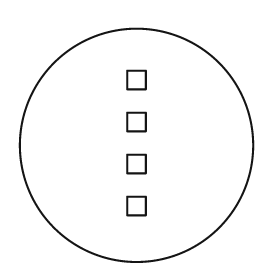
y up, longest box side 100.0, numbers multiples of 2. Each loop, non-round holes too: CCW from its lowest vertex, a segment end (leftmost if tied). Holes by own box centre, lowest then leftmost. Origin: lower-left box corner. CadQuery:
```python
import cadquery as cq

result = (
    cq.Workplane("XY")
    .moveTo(50.0, 50.0)
    .circle(50.0)
    .moveTo(46.0, 20.0)
    .lineTo(54.0, 20.0)
    .lineTo(54.0, 28.0)
    .lineTo(46.0, 28.0)
    .close()
    .moveTo(46.0, 38.0)
    .lineTo(54.0, 38.0)
    .lineTo(54.0, 46.0)
    .lineTo(46.0, 46.0)
    .close()
    .moveTo(46.0, 56.0)
    .lineTo(54.0, 56.0)
    .lineTo(54.0, 64.0)
    .lineTo(46.0, 64.0)
    .close()
    .moveTo(46.0, 74.0)
    .lineTo(54.0, 74.0)
    .lineTo(54.0, 82.0)
    .lineTo(46.0, 82.0)
    .close()
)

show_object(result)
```